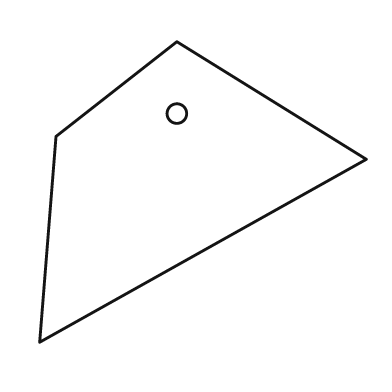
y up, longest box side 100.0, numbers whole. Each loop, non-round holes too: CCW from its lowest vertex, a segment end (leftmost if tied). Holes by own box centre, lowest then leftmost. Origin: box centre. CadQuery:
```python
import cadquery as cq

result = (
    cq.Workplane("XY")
    .moveTo(-50.0, -46.0)
    .lineTo(50.0, 10.0)
    .lineTo(-8.0, 46.0)
    .lineTo(-45.0, 17.0)
    .close()
    .moveTo(-8.0, 24.0)
    .circle(3.0)
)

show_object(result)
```